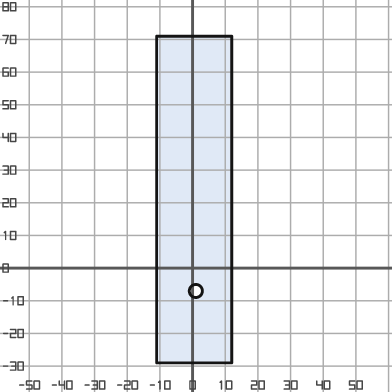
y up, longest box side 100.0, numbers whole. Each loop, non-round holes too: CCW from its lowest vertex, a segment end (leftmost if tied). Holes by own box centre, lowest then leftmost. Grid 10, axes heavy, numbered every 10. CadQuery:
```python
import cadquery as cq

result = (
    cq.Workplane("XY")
    .moveTo(-11.0, -29.0)
    .lineTo(12.0, -29.0)
    .lineTo(12.0, 71.0)
    .lineTo(-11.0, 71.0)
    .close()
    .moveTo(1.0, -7.0)
    .circle(2.0)
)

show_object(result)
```